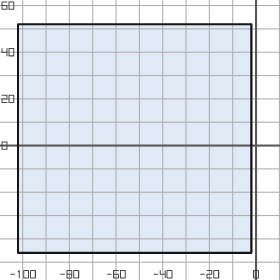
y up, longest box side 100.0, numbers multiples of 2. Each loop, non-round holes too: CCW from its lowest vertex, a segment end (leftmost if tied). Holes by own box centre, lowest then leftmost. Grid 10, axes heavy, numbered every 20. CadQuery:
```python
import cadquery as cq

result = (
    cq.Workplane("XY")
    .moveTo(-102.0, -46.0)
    .lineTo(-2.0, -46.0)
    .lineTo(-2.0, 52.0)
    .lineTo(-102.0, 52.0)
    .close()
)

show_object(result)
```